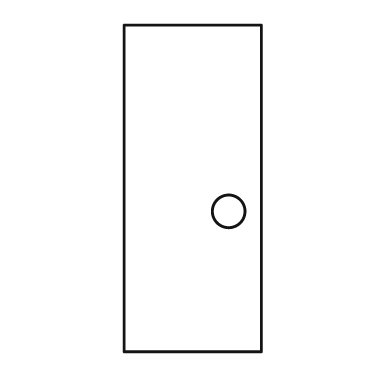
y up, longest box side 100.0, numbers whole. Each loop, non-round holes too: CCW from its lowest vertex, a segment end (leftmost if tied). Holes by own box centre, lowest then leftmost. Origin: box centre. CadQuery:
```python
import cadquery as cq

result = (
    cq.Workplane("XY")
    .moveTo(-21.0, -50.0)
    .lineTo(21.0, -50.0)
    .lineTo(21.0, 50.0)
    .lineTo(-21.0, 50.0)
    .close()
    .moveTo(11.0, -7.0)
    .circle(5.0)
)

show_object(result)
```